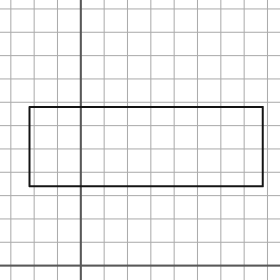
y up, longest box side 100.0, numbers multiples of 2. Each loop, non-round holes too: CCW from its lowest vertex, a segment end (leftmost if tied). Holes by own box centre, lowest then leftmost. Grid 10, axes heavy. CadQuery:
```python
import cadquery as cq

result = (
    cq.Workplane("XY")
    .moveTo(-22.0, 34.0)
    .lineTo(78.0, 34.0)
    .lineTo(78.0, 68.0)
    .lineTo(-22.0, 68.0)
    .close()
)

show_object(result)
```